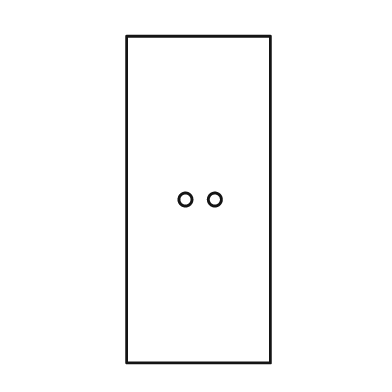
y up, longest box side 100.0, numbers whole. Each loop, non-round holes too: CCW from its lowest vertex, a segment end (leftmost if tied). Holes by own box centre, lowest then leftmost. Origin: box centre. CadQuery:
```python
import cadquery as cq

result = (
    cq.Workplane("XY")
    .moveTo(-22.0, -50.0)
    .lineTo(22.0, -50.0)
    .lineTo(22.0, 50.0)
    .lineTo(-22.0, 50.0)
    .close()
    .moveTo(-4.0, 0.0)
    .circle(2.0)
    .moveTo(5.0, 0.0)
    .circle(2.0)
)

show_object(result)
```